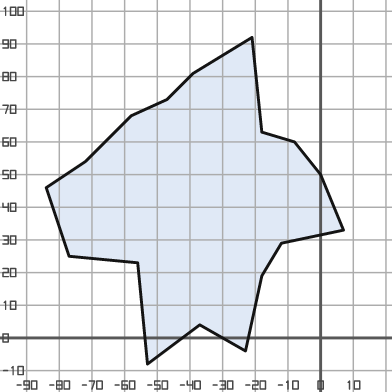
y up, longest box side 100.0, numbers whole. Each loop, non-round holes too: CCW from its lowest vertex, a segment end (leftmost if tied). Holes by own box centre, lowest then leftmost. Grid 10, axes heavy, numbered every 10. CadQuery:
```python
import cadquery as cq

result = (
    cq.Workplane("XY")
    .moveTo(-53.0, -8.0)
    .lineTo(-37.0, 4.0)
    .lineTo(-23.0, -4.0)
    .lineTo(-18.0, 19.0)
    .lineTo(-12.0, 29.0)
    .lineTo(7.0, 33.0)
    .lineTo(0.0, 50.0)
    .lineTo(-8.0, 60.0)
    .lineTo(-18.0, 63.0)
    .lineTo(-21.0, 92.0)
    .lineTo(-39.0, 81.0)
    .lineTo(-47.0, 73.0)
    .lineTo(-58.0, 68.0)
    .lineTo(-72.0, 54.0)
    .lineTo(-84.0, 46.0)
    .lineTo(-77.0, 25.0)
    .lineTo(-56.0, 23.0)
    .close()
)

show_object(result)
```